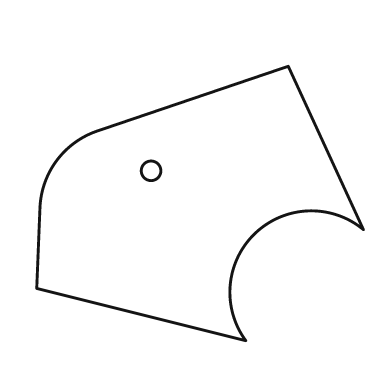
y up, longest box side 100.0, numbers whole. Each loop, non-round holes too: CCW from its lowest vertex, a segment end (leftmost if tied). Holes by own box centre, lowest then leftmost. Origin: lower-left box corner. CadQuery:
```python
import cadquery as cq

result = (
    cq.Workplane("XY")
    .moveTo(64.0, 0.0)
    .threePointArc((67.0, 33.0), (100.0, 34.0))
    .lineTo(77.0, 84.0)
    .lineTo(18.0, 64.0)
    .threePointArc((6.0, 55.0), (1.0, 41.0))
    .lineTo(0.0, 16.0)
    .close()
    .moveTo(35.0, 52.0)
    .circle(3.0)
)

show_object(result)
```